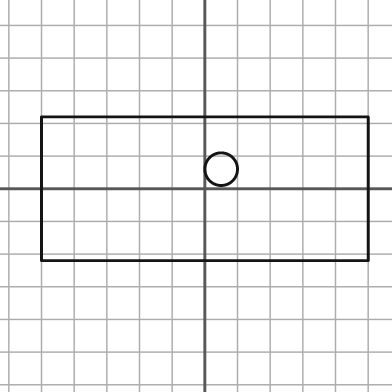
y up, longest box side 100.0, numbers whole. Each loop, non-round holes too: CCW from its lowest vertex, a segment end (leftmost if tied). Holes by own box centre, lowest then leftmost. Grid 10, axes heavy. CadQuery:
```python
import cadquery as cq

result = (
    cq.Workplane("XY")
    .moveTo(-50.0, -22.0)
    .lineTo(50.0, -22.0)
    .lineTo(50.0, 22.0)
    .lineTo(-50.0, 22.0)
    .close()
    .moveTo(5.0, 6.0)
    .circle(5.0)
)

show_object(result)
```